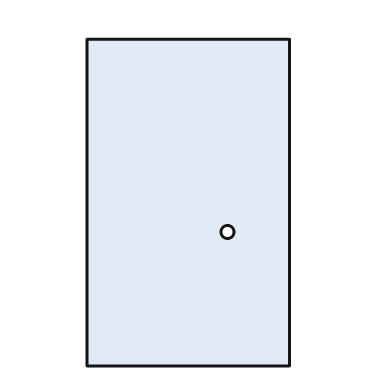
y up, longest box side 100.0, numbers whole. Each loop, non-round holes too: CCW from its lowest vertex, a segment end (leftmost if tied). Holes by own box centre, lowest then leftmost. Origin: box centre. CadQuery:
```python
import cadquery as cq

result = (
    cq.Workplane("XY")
    .moveTo(-31.0, -50.0)
    .lineTo(31.0, -50.0)
    .lineTo(31.0, 50.0)
    .lineTo(-31.0, 50.0)
    .close()
    .moveTo(12.0, -9.0)
    .circle(2.0)
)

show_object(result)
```